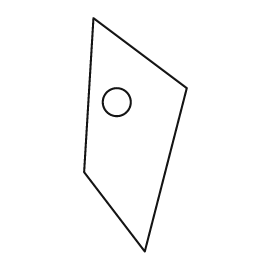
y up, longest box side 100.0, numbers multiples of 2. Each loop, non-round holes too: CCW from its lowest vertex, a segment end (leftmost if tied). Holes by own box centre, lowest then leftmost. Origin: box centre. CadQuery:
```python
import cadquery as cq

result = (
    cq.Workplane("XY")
    .moveTo(4.0, -50.0)
    .lineTo(22.0, 20.0)
    .lineTo(-18.0, 50.0)
    .lineTo(-22.0, -16.0)
    .close()
    .moveTo(-8.0, 14.0)
    .circle(6.0)
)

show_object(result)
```